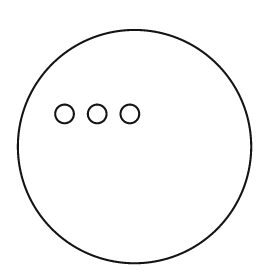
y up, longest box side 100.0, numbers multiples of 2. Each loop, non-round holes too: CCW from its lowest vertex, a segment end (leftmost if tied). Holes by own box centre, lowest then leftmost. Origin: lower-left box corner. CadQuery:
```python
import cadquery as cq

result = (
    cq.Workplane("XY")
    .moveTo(50.0, 50.0)
    .circle(50.0)
    .moveTo(20.0, 64.0)
    .circle(4.0)
    .moveTo(34.0, 64.0)
    .circle(4.0)
    .moveTo(48.0, 64.0)
    .circle(4.0)
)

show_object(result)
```